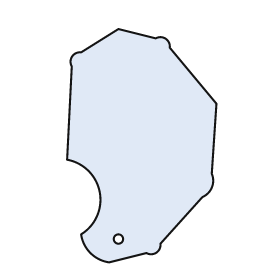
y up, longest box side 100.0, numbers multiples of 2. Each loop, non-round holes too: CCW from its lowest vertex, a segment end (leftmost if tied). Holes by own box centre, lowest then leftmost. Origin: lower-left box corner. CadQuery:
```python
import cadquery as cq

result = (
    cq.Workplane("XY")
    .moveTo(18.0, 0.0)
    .lineTo(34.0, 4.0)
    .threePointArc((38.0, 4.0), (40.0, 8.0))
    .lineTo(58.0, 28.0)
    .threePointArc((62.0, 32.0), (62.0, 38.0))
    .lineTo(64.0, 68.0)
    .lineTo(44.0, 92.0)
    .threePointArc((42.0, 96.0), (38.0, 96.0))
    .lineTo(22.0, 100.0)
    .lineTo(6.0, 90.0)
    .threePointArc((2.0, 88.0), (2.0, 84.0))
    .lineTo(0.0, 44.0)
    .threePointArc((14.0, 30.0), (6.0, 12.0))
    .threePointArc((10.0, 4.0), (18.0, 0.0))
    .close()
    .moveTo(22.0, 10.0)
    .circle(2.0)
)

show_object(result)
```